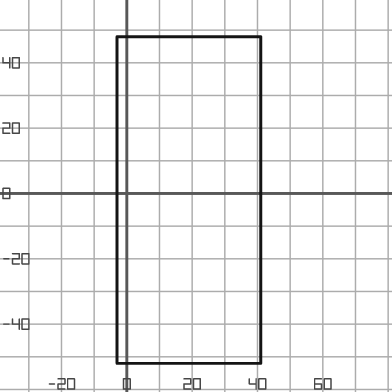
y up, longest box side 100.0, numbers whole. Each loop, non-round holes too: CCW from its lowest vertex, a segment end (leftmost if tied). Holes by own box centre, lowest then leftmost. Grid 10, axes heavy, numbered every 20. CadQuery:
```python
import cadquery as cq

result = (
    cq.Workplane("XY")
    .moveTo(-3.0, -52.0)
    .lineTo(41.0, -52.0)
    .lineTo(41.0, 48.0)
    .lineTo(-3.0, 48.0)
    .close()
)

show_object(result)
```